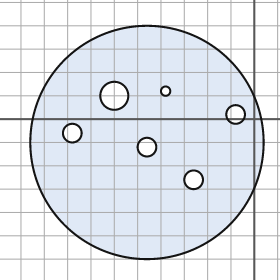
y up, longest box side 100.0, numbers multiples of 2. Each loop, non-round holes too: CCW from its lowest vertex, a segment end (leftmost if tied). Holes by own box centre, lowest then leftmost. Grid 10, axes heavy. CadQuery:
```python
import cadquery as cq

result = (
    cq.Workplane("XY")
    .moveTo(-46.0, -10.0)
    .circle(50.0)
    .moveTo(-26.0, -26.0)
    .circle(4.0)
    .moveTo(-46.0, -12.0)
    .circle(4.0)
    .moveTo(-78.0, -6.0)
    .circle(4.0)
    .moveTo(-8.0, 2.0)
    .circle(4.0)
    .moveTo(-60.0, 10.0)
    .circle(6.0)
    .moveTo(-38.0, 12.0)
    .circle(2.0)
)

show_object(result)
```